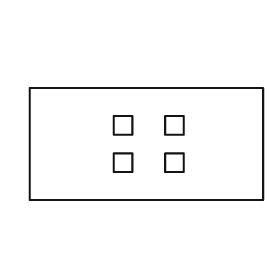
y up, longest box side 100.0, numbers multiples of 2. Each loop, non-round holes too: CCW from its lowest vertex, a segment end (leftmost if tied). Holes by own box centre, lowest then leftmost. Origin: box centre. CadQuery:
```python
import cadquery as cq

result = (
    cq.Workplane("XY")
    .moveTo(-50.0, -24.0)
    .lineTo(50.0, -24.0)
    .lineTo(50.0, 24.0)
    .lineTo(-50.0, 24.0)
    .close()
    .moveTo(-14.0, -12.0)
    .lineTo(-6.0, -12.0)
    .lineTo(-6.0, -4.0)
    .lineTo(-14.0, -4.0)
    .close()
    .moveTo(8.0, -12.0)
    .lineTo(16.0, -12.0)
    .lineTo(16.0, -4.0)
    .lineTo(8.0, -4.0)
    .close()
    .moveTo(-14.0, 4.0)
    .lineTo(-6.0, 4.0)
    .lineTo(-6.0, 12.0)
    .lineTo(-14.0, 12.0)
    .close()
    .moveTo(8.0, 4.0)
    .lineTo(16.0, 4.0)
    .lineTo(16.0, 12.0)
    .lineTo(8.0, 12.0)
    .close()
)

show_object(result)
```